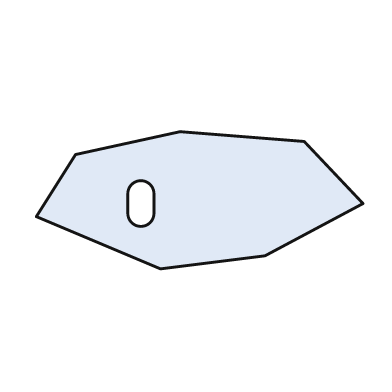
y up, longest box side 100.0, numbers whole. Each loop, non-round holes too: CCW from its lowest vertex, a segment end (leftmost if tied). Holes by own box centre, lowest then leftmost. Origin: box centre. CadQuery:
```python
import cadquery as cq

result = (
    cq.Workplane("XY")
    .moveTo(-12.0, -21.0)
    .lineTo(20.0, -17.0)
    .lineTo(50.0, -1.0)
    .lineTo(32.0, 18.0)
    .lineTo(-6.0, 21.0)
    .lineTo(-38.0, 14.0)
    .lineTo(-50.0, -5.0)
    .close()
    .moveTo(-22.0, -4.0)
    .threePointArc((-18.0, -8.0), (-14.0, -4.0))
    .lineTo(-14.0, 2.0)
    .threePointArc((-18.0, 6.0), (-22.0, 2.0))
    .close()
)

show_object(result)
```